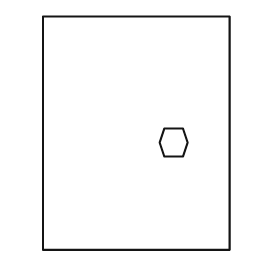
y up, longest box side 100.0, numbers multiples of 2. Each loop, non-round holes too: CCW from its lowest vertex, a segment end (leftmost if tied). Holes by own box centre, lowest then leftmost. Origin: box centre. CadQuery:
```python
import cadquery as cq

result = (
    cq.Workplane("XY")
    .moveTo(-40.0, -50.0)
    .lineTo(40.0, -50.0)
    .lineTo(40.0, 50.0)
    .lineTo(-40.0, 50.0)
    .close()
    .moveTo(12.0, -10.0)
    .lineTo(20.0, -10.0)
    .lineTo(22.0, -4.0)
    .lineTo(20.0, 2.0)
    .lineTo(12.0, 2.0)
    .lineTo(10.0, -4.0)
    .close()
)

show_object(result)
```